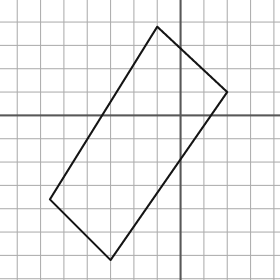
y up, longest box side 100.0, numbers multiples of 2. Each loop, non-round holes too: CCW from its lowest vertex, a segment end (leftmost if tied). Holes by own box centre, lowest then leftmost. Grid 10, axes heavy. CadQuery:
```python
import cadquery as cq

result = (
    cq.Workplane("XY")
    .moveTo(-30.0, -62.0)
    .lineTo(20.0, 10.0)
    .lineTo(-10.0, 38.0)
    .lineTo(-56.0, -36.0)
    .close()
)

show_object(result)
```